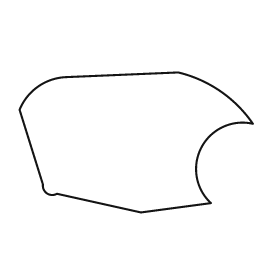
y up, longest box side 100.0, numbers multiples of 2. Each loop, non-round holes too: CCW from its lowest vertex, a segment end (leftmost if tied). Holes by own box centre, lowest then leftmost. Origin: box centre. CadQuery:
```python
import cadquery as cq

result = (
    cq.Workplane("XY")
    .moveTo(2.0, -30.0)
    .lineTo(32.0, -26.0)
    .threePointArc((28.0, -2.0), (50.0, 8.0))
    .threePointArc((36.0, 22.0), (18.0, 30.0))
    .lineTo(-30.0, 28.0)
    .threePointArc((-42.0, 24.0), (-50.0, 14.0))
    .lineTo(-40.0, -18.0)
    .threePointArc((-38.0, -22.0), (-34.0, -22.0))
    .close()
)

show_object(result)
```